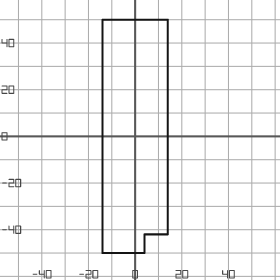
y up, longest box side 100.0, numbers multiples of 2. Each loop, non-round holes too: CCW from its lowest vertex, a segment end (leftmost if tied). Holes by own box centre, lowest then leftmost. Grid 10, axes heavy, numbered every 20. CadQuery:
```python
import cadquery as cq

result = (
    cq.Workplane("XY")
    .moveTo(-14.0, -50.0)
    .lineTo(4.0, -50.0)
    .lineTo(4.0, -42.0)
    .lineTo(14.0, -42.0)
    .lineTo(14.0, 50.0)
    .lineTo(-14.0, 50.0)
    .close()
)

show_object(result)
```